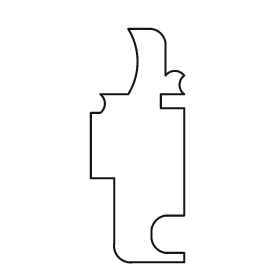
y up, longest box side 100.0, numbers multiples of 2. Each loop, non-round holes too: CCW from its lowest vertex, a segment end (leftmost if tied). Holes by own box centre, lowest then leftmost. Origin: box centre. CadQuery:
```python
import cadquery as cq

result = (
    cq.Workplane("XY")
    .moveTo(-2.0, -50.0)
    .lineTo(20.0, -50.0)
    .lineTo(20.0, -46.0)
    .lineTo(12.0, -46.0)
    .threePointArc((8.0, -44.0), (6.0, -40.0))
    .lineTo(6.0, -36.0)
    .threePointArc((8.0, -32.0), (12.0, -30.0))
    .lineTo(20.0, -30.0)
    .lineTo(20.0, 16.0)
    .lineTo(10.0, 16.0)
    .lineTo(10.0, 22.0)
    .lineTo(20.0, 22.0)
    .threePointArc((18.0, 26.0), (20.0, 30.0))
    .threePointArc((16.0, 32.0), (12.0, 30.0))
    .lineTo(12.0, 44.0)
    .threePointArc((10.0, 48.0), (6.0, 50.0))
    .lineTo(-4.0, 50.0)
    .threePointArc((0.0, 36.0), (-4.0, 22.0))
    .lineTo(-16.0, 22.0)
    .threePointArc((-14.0, 18.0), (-16.0, 14.0))
    .lineTo(-20.0, 14.0)
    .lineTo(-20.0, -14.0)
    .lineTo(-10.0, -14.0)
    .lineTo(-10.0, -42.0)
    .threePointArc((-8.0, -48.0), (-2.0, -50.0))
    .close()
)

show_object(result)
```